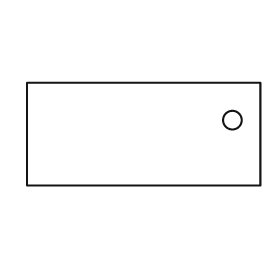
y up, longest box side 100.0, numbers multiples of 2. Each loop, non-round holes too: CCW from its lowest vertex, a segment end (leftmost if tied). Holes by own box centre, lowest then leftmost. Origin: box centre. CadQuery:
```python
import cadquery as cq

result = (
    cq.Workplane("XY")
    .moveTo(-50.0, -22.0)
    .lineTo(50.0, -22.0)
    .lineTo(50.0, 22.0)
    .lineTo(-50.0, 22.0)
    .close()
    .moveTo(38.0, 6.0)
    .circle(4.0)
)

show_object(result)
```